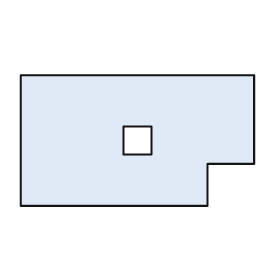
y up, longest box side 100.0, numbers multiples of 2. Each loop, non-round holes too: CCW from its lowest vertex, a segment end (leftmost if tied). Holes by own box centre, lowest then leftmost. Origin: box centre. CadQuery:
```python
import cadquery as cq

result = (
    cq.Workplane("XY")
    .moveTo(-50.0, -28.0)
    .lineTo(30.0, -28.0)
    .lineTo(30.0, -10.0)
    .lineTo(50.0, -10.0)
    .lineTo(50.0, 28.0)
    .lineTo(-50.0, 28.0)
    .close()
    .moveTo(-6.0, -6.0)
    .lineTo(6.0, -6.0)
    .lineTo(6.0, 6.0)
    .lineTo(-6.0, 6.0)
    .close()
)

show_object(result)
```